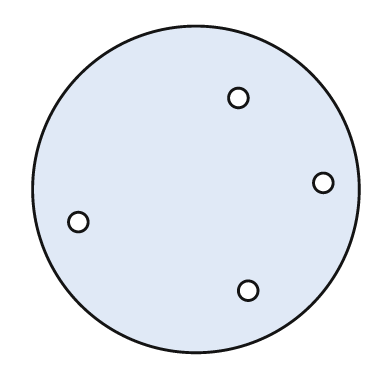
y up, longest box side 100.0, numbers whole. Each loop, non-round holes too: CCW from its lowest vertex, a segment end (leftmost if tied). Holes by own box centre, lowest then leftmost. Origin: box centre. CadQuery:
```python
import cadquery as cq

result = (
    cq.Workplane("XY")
    .moveTo(0.0, 0.0)
    .circle(50.0)
    .moveTo(16.0, -31.0)
    .circle(3.0)
    .moveTo(-36.0, -10.0)
    .circle(3.0)
    .moveTo(39.0, 2.0)
    .circle(3.0)
    .moveTo(13.0, 28.0)
    .circle(3.0)
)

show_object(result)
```